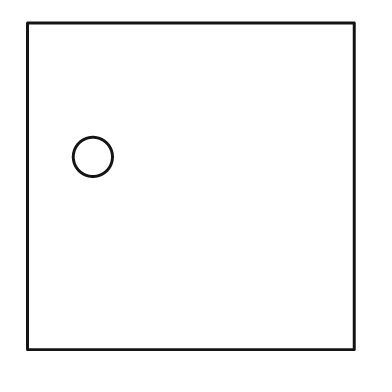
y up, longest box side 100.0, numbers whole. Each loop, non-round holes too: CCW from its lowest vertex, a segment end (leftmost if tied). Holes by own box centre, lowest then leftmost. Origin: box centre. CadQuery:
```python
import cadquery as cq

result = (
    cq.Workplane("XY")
    .moveTo(-50.0, -50.0)
    .lineTo(50.0, -50.0)
    .lineTo(50.0, 50.0)
    .lineTo(-50.0, 50.0)
    .close()
    .moveTo(-30.0, 9.0)
    .circle(6.0)
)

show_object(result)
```